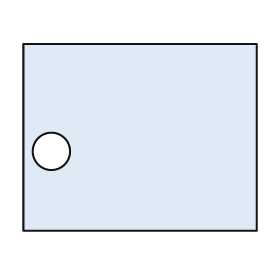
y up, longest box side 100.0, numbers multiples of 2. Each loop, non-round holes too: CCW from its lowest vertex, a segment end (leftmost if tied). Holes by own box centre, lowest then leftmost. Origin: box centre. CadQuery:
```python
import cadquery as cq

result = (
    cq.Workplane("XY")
    .moveTo(-50.0, -40.0)
    .lineTo(50.0, -40.0)
    .lineTo(50.0, 40.0)
    .lineTo(-50.0, 40.0)
    .close()
    .moveTo(-38.0, -6.0)
    .circle(8.0)
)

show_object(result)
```